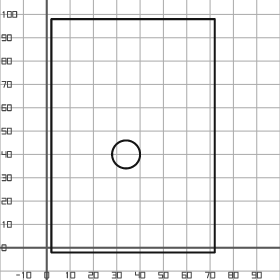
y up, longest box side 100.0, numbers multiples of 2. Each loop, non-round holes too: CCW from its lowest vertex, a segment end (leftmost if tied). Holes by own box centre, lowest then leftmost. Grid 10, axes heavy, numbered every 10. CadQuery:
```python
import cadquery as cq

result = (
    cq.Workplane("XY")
    .moveTo(2.0, -2.0)
    .lineTo(72.0, -2.0)
    .lineTo(72.0, 98.0)
    .lineTo(2.0, 98.0)
    .close()
    .moveTo(34.0, 40.0)
    .circle(6.0)
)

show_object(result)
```